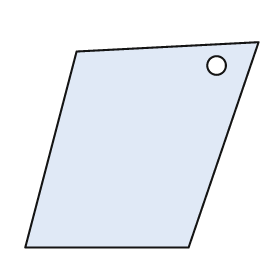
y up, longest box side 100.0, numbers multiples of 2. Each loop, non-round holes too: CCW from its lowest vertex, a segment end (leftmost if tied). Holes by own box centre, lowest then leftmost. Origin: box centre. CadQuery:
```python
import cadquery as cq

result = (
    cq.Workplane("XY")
    .moveTo(-50.0, -44.0)
    .lineTo(20.0, -44.0)
    .lineTo(50.0, 44.0)
    .lineTo(-28.0, 40.0)
    .close()
    .moveTo(32.0, 34.0)
    .circle(4.0)
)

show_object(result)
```